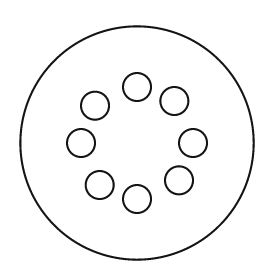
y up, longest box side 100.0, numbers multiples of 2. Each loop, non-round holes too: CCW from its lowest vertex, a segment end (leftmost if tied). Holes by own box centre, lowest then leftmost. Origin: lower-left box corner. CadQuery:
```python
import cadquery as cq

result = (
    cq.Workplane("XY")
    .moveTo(50.0, 50.0)
    .circle(50.0)
    .moveTo(50.0, 26.0)
    .circle(6.0)
    .moveTo(34.0, 32.0)
    .circle(6.0)
    .moveTo(68.0, 34.0)
    .circle(6.0)
    .moveTo(26.0, 50.0)
    .circle(6.0)
    .moveTo(74.0, 50.0)
    .circle(6.0)
    .moveTo(32.0, 66.0)
    .circle(6.0)
    .moveTo(66.0, 68.0)
    .circle(6.0)
    .moveTo(50.0, 74.0)
    .circle(6.0)
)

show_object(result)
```